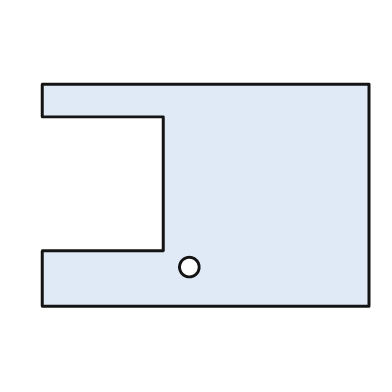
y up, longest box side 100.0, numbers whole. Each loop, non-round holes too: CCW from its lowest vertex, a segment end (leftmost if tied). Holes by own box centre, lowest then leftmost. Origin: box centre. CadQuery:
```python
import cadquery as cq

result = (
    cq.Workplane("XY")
    .moveTo(-50.0, -34.0)
    .lineTo(50.0, -34.0)
    .lineTo(50.0, 34.0)
    .lineTo(-50.0, 34.0)
    .lineTo(-50.0, 24.0)
    .lineTo(-13.0, 24.0)
    .lineTo(-13.0, -17.0)
    .lineTo(-50.0, -17.0)
    .close()
    .moveTo(-5.0, -22.0)
    .circle(3.0)
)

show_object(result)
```